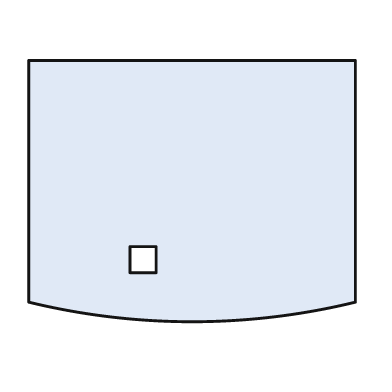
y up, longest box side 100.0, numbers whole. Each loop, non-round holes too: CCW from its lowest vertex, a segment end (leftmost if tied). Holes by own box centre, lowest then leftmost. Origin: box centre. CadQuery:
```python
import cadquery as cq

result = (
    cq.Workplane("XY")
    .moveTo(-50.0, -34.0)
    .threePointArc((0.0, -40.0), (50.0, -34.0))
    .lineTo(50.0, 40.0)
    .lineTo(-50.0, 40.0)
    .close()
    .moveTo(-19.0, -25.0)
    .lineTo(-11.0, -25.0)
    .lineTo(-11.0, -17.0)
    .lineTo(-19.0, -17.0)
    .close()
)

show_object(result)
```